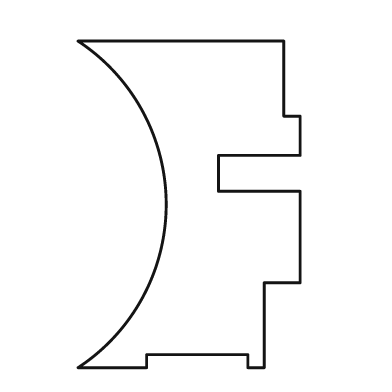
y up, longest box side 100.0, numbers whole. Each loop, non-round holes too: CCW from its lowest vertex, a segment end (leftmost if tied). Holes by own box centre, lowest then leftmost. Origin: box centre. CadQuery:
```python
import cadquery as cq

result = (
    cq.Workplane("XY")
    .moveTo(-34.0, -50.0)
    .lineTo(-13.0, -50.0)
    .lineTo(-13.0, -46.0)
    .lineTo(18.0, -46.0)
    .lineTo(18.0, -50.0)
    .lineTo(23.0, -50.0)
    .lineTo(23.0, -24.0)
    .lineTo(34.0, -24.0)
    .lineTo(34.0, 4.0)
    .lineTo(9.0, 4.0)
    .lineTo(9.0, 15.0)
    .lineTo(34.0, 15.0)
    .lineTo(34.0, 27.0)
    .lineTo(29.0, 27.0)
    .lineTo(29.0, 50.0)
    .lineTo(-34.0, 50.0)
    .threePointArc((-7.0, 0.0), (-34.0, -50.0))
    .close()
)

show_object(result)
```